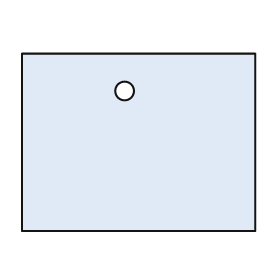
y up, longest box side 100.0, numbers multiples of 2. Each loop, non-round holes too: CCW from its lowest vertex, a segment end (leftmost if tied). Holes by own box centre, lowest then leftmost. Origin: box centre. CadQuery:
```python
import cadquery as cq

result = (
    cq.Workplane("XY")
    .moveTo(-50.0, -38.0)
    .lineTo(50.0, -38.0)
    .lineTo(50.0, 38.0)
    .lineTo(-50.0, 38.0)
    .close()
    .moveTo(-6.0, 22.0)
    .circle(4.0)
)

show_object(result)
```